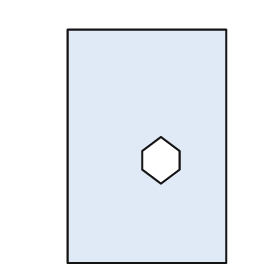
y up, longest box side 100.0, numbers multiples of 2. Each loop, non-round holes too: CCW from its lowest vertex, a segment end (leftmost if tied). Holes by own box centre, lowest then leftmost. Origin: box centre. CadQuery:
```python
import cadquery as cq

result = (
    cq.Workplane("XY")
    .moveTo(-34.0, -50.0)
    .lineTo(34.0, -50.0)
    .lineTo(34.0, 50.0)
    .lineTo(-34.0, 50.0)
    .close()
    .moveTo(6.0, -16.0)
    .lineTo(14.0, -10.0)
    .lineTo(14.0, -2.0)
    .lineTo(6.0, 4.0)
    .lineTo(-2.0, -2.0)
    .lineTo(-2.0, -10.0)
    .close()
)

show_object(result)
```